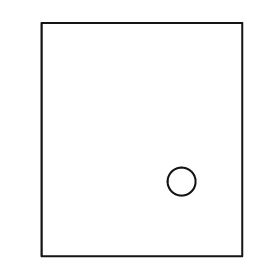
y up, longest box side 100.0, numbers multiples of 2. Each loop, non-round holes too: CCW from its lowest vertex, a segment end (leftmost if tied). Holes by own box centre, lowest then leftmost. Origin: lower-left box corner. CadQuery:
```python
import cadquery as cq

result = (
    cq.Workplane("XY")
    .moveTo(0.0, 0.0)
    .lineTo(86.0, 0.0)
    .lineTo(86.0, 100.0)
    .lineTo(0.0, 100.0)
    .close()
    .moveTo(60.0, 32.0)
    .circle(6.0)
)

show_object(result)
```